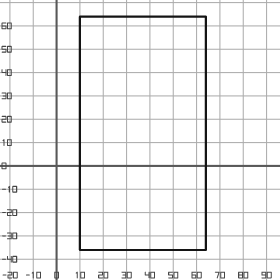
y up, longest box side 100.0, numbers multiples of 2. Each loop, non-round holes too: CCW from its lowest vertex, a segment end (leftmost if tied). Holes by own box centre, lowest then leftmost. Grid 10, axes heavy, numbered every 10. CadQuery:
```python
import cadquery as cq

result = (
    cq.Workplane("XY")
    .moveTo(10.0, -36.0)
    .lineTo(64.0, -36.0)
    .lineTo(64.0, 64.0)
    .lineTo(10.0, 64.0)
    .close()
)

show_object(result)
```